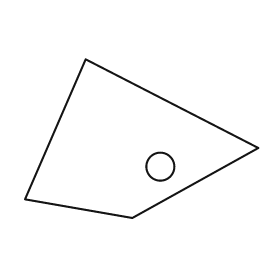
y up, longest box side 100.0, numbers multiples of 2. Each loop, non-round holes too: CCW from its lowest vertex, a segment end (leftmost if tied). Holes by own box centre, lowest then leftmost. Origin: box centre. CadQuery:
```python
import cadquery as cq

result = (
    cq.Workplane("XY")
    .moveTo(-4.0, -34.0)
    .lineTo(50.0, -4.0)
    .lineTo(-24.0, 34.0)
    .lineTo(-50.0, -26.0)
    .close()
    .moveTo(8.0, -12.0)
    .circle(6.0)
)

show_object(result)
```